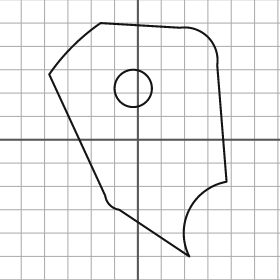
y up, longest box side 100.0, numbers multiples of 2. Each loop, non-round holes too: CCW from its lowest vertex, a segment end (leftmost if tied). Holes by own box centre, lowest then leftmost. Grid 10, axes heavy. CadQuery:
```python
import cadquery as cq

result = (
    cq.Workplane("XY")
    .moveTo(22.0, -50.0)
    .threePointArc((22.0, -30.0), (38.0, -18.0))
    .lineTo(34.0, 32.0)
    .threePointArc((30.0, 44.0), (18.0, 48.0))
    .lineTo(-16.0, 50.0)
    .threePointArc((-28.0, 40.0), (-38.0, 28.0))
    .lineTo(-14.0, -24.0)
    .threePointArc((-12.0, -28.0), (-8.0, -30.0))
    .close()
    .moveTo(-2.0, 22.0)
    .circle(8.0)
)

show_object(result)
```